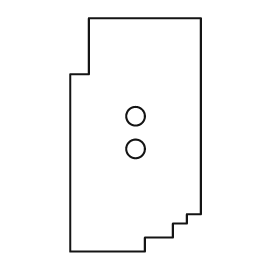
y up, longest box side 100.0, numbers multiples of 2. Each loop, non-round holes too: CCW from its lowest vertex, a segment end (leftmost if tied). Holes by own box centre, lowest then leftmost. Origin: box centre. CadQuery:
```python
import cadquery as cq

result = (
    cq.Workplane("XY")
    .moveTo(-28.0, -50.0)
    .lineTo(4.0, -50.0)
    .lineTo(4.0, -44.0)
    .lineTo(16.0, -44.0)
    .lineTo(16.0, -38.0)
    .lineTo(22.0, -38.0)
    .lineTo(22.0, -34.0)
    .lineTo(28.0, -34.0)
    .lineTo(28.0, 50.0)
    .lineTo(-20.0, 50.0)
    .lineTo(-20.0, 26.0)
    .lineTo(-28.0, 26.0)
    .close()
    .moveTo(0.0, -6.0)
    .circle(4.0)
    .moveTo(0.0, 8.0)
    .circle(4.0)
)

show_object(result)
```